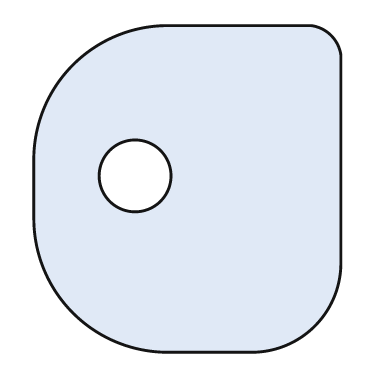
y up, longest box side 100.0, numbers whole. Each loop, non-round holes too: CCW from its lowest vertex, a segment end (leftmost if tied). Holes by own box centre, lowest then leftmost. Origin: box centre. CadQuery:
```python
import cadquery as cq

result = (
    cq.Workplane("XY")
    .moveTo(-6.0, -50.0)
    .lineTo(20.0, -50.0)
    .threePointArc((39.0, -42.0), (47.0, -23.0))
    .lineTo(47.0, 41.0)
    .threePointArc((44.0, 47.0), (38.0, 50.0))
    .lineTo(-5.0, 50.0)
    .threePointArc((-35.0, 38.0), (-47.0, 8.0))
    .lineTo(-47.0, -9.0)
    .threePointArc((-35.0, -38.0), (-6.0, -50.0))
    .close()
    .moveTo(-16.0, 4.0)
    .circle(11.0)
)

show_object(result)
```